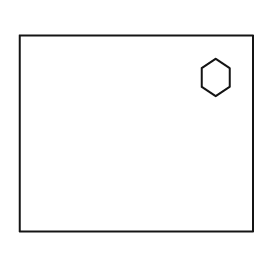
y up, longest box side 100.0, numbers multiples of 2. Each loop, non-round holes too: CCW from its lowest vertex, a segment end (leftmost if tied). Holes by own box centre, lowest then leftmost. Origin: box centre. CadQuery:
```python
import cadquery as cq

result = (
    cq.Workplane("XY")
    .moveTo(-50.0, -42.0)
    .lineTo(50.0, -42.0)
    .lineTo(50.0, 42.0)
    .lineTo(-50.0, 42.0)
    .close()
    .moveTo(34.0, 16.0)
    .lineTo(40.0, 20.0)
    .lineTo(40.0, 28.0)
    .lineTo(34.0, 32.0)
    .lineTo(28.0, 28.0)
    .lineTo(28.0, 20.0)
    .close()
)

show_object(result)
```